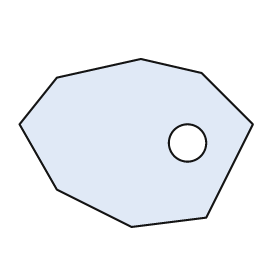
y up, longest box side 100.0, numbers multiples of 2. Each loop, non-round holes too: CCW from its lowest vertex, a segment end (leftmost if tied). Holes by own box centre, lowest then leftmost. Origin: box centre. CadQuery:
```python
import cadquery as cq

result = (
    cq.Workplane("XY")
    .moveTo(-2.0, -36.0)
    .lineTo(30.0, -32.0)
    .lineTo(50.0, 8.0)
    .lineTo(28.0, 30.0)
    .lineTo(2.0, 36.0)
    .lineTo(-34.0, 28.0)
    .lineTo(-50.0, 8.0)
    .lineTo(-34.0, -20.0)
    .close()
    .moveTo(22.0, 0.0)
    .circle(8.0)
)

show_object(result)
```